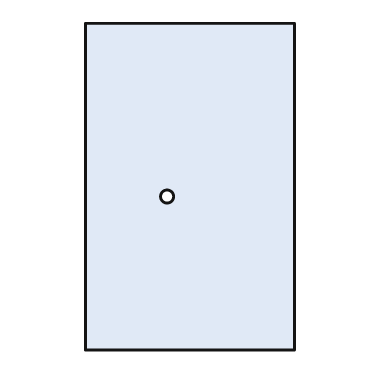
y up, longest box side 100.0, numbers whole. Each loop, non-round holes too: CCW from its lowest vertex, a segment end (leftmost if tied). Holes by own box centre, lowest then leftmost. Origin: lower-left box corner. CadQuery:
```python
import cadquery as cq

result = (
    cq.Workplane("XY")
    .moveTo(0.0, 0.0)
    .lineTo(64.0, 0.0)
    .lineTo(64.0, 100.0)
    .lineTo(0.0, 100.0)
    .close()
    .moveTo(25.0, 47.0)
    .circle(2.0)
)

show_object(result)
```